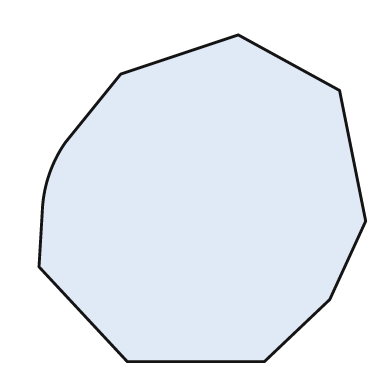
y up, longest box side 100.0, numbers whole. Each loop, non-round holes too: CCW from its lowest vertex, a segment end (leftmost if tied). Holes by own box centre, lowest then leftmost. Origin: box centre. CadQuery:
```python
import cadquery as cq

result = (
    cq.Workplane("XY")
    .moveTo(-23.0, -50.0)
    .lineTo(19.0, -50.0)
    .lineTo(39.0, -31.0)
    .lineTo(50.0, -7.0)
    .lineTo(42.0, 33.0)
    .lineTo(11.0, 50.0)
    .lineTo(-25.0, 38.0)
    .lineTo(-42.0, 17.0)
    .threePointArc((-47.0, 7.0), (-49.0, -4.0))
    .lineTo(-50.0, -21.0)
    .close()
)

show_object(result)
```